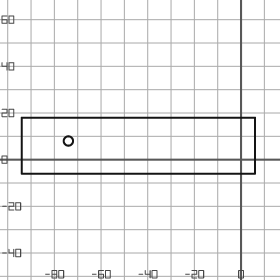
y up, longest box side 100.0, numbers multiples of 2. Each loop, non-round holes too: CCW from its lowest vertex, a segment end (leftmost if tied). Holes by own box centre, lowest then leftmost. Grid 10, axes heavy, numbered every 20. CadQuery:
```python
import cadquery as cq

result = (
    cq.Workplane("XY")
    .moveTo(-94.0, -6.0)
    .lineTo(6.0, -6.0)
    .lineTo(6.0, 18.0)
    .lineTo(-94.0, 18.0)
    .close()
    .moveTo(-74.0, 8.0)
    .circle(2.0)
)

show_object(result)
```